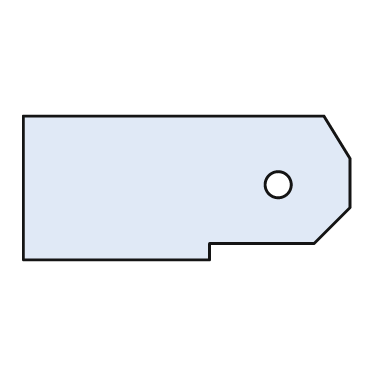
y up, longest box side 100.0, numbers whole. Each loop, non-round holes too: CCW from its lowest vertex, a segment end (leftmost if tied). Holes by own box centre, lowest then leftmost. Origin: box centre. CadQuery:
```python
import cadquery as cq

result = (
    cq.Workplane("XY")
    .moveTo(-50.0, -22.0)
    .lineTo(7.0, -22.0)
    .lineTo(7.0, -17.0)
    .lineTo(39.0, -17.0)
    .lineTo(50.0, -6.0)
    .lineTo(50.0, 9.0)
    .lineTo(42.0, 22.0)
    .lineTo(-50.0, 22.0)
    .close()
    .moveTo(28.0, 1.0)
    .circle(4.0)
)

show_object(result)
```